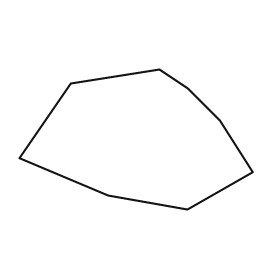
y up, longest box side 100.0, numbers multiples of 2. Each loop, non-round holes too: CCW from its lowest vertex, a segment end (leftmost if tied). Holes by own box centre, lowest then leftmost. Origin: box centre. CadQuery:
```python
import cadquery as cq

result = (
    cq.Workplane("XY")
    .moveTo(22.0, -30.0)
    .lineTo(50.0, -14.0)
    .lineTo(36.0, 8.0)
    .lineTo(22.0, 22.0)
    .lineTo(10.0, 30.0)
    .lineTo(-28.0, 24.0)
    .lineTo(-50.0, -8.0)
    .lineTo(-12.0, -24.0)
    .close()
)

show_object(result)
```